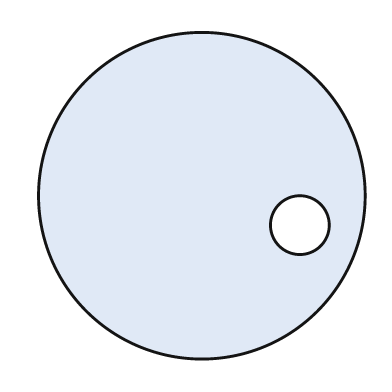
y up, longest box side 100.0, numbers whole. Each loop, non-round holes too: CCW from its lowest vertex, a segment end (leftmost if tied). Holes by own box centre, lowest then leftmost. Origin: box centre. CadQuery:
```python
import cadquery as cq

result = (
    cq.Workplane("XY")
    .moveTo(0.0, 0.0)
    .circle(50.0)
    .moveTo(30.0, -9.0)
    .circle(9.0)
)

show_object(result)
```